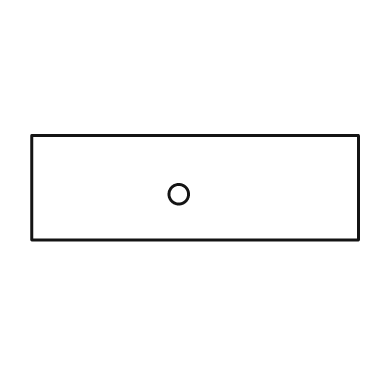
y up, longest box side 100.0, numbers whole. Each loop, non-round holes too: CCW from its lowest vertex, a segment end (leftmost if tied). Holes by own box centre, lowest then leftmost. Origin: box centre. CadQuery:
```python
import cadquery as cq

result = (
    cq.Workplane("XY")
    .moveTo(-50.0, -16.0)
    .lineTo(50.0, -16.0)
    .lineTo(50.0, 16.0)
    .lineTo(-50.0, 16.0)
    .close()
    .moveTo(-5.0, -2.0)
    .circle(3.0)
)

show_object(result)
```